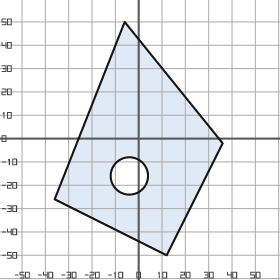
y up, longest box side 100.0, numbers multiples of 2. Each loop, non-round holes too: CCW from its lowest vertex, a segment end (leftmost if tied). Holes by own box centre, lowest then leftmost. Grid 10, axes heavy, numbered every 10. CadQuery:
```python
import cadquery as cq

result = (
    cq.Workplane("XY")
    .moveTo(12.0, -50.0)
    .lineTo(36.0, -2.0)
    .lineTo(-6.0, 50.0)
    .lineTo(-36.0, -26.0)
    .close()
    .moveTo(-4.0, -16.0)
    .circle(8.0)
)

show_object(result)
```